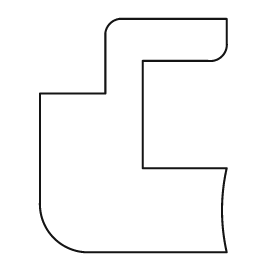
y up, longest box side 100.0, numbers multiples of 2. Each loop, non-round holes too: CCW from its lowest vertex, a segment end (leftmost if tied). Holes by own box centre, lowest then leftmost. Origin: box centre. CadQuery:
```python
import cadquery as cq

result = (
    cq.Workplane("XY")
    .moveTo(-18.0, -50.0)
    .lineTo(40.0, -50.0)
    .threePointArc((38.0, -32.0), (40.0, -14.0))
    .lineTo(4.0, -14.0)
    .lineTo(4.0, 32.0)
    .lineTo(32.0, 32.0)
    .threePointArc((38.0, 34.0), (40.0, 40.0))
    .lineTo(40.0, 50.0)
    .lineTo(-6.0, 50.0)
    .threePointArc((-10.0, 48.0), (-12.0, 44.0))
    .lineTo(-12.0, 18.0)
    .lineTo(-40.0, 18.0)
    .lineTo(-40.0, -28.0)
    .threePointArc((-34.0, -44.0), (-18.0, -50.0))
    .close()
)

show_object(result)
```